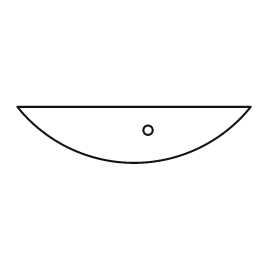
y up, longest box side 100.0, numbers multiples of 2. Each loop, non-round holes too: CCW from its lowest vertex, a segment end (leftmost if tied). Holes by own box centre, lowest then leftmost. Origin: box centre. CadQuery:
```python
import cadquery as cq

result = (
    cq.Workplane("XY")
    .moveTo(-50.0, 12.0)
    .threePointArc((0.0, -12.0), (50.0, 12.0))
    .close()
    .moveTo(6.0, 2.0)
    .circle(2.0)
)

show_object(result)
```